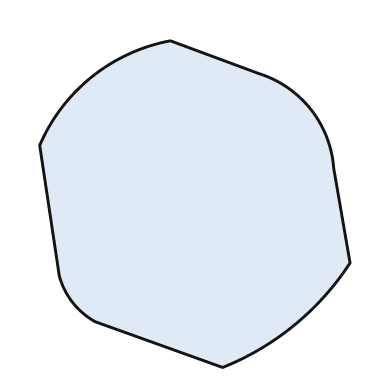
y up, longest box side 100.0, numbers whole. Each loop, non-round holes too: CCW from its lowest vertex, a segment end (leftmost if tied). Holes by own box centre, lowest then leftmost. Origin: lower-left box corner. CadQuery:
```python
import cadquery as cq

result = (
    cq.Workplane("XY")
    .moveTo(56.0, 0.0)
    .threePointArc((78.0, 13.0), (95.0, 32.0))
    .lineTo(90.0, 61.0)
    .threePointArc((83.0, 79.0), (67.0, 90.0))
    .lineTo(40.0, 100.0)
    .threePointArc((16.0, 89.0), (0.0, 68.0))
    .lineTo(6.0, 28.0)
    .threePointArc((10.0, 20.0), (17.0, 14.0))
    .close()
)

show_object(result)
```